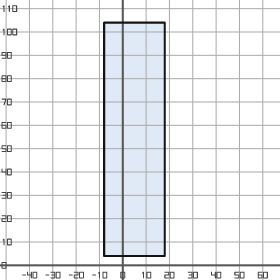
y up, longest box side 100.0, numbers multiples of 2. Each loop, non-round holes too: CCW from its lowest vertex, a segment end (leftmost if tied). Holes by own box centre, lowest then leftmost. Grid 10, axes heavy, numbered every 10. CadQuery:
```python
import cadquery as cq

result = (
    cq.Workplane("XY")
    .moveTo(-8.0, 4.0)
    .lineTo(18.0, 4.0)
    .lineTo(18.0, 104.0)
    .lineTo(-8.0, 104.0)
    .close()
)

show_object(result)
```